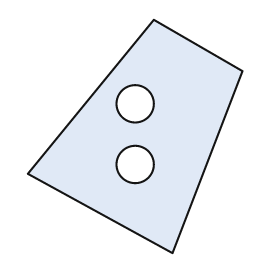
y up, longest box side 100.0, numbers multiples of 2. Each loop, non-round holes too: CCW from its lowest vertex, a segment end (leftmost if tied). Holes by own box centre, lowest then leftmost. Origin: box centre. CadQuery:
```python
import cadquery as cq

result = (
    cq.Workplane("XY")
    .moveTo(16.0, -50.0)
    .lineTo(46.0, 28.0)
    .lineTo(8.0, 50.0)
    .lineTo(-46.0, -16.0)
    .close()
    .moveTo(0.0, -12.0)
    .circle(8.0)
    .moveTo(0.0, 14.0)
    .circle(8.0)
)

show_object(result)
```